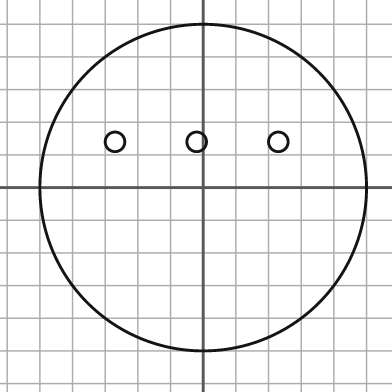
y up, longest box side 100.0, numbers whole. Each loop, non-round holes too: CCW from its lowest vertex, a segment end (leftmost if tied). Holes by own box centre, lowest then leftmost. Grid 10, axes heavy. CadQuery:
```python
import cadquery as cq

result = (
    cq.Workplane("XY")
    .moveTo(0.0, 0.0)
    .circle(50.0)
    .moveTo(-27.0, 14.0)
    .circle(3.0)
    .moveTo(-2.0, 14.0)
    .circle(3.0)
    .moveTo(23.0, 14.0)
    .circle(3.0)
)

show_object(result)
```